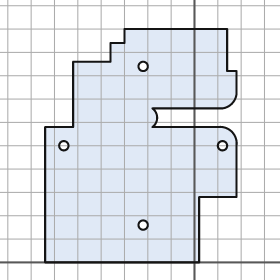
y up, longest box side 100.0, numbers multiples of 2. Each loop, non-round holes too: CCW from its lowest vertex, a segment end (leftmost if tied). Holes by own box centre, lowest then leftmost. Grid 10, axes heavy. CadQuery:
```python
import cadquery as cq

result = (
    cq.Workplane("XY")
    .moveTo(-64.0, 0.0)
    .lineTo(2.0, 0.0)
    .lineTo(2.0, 28.0)
    .lineTo(18.0, 28.0)
    .lineTo(18.0, 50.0)
    .threePointArc((16.0, 56.0), (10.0, 58.0))
    .lineTo(-18.0, 58.0)
    .threePointArc((-16.0, 62.0), (-18.0, 66.0))
    .lineTo(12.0, 66.0)
    .threePointArc((16.0, 68.0), (18.0, 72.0))
    .lineTo(18.0, 82.0)
    .lineTo(14.0, 82.0)
    .lineTo(14.0, 100.0)
    .lineTo(-30.0, 100.0)
    .lineTo(-30.0, 94.0)
    .lineTo(-36.0, 94.0)
    .lineTo(-36.0, 86.0)
    .lineTo(-52.0, 86.0)
    .lineTo(-52.0, 58.0)
    .lineTo(-64.0, 58.0)
    .close()
    .moveTo(-22.0, 16.0)
    .circle(2.0)
    .moveTo(-56.0, 50.0)
    .circle(2.0)
    .moveTo(12.0, 50.0)
    .circle(2.0)
    .moveTo(-22.0, 84.0)
    .circle(2.0)
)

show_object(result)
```